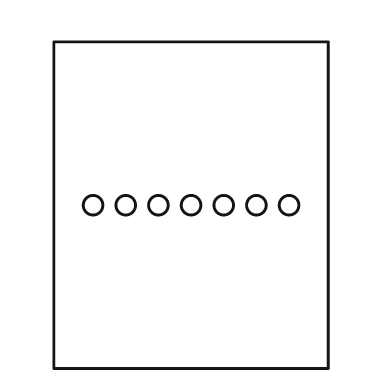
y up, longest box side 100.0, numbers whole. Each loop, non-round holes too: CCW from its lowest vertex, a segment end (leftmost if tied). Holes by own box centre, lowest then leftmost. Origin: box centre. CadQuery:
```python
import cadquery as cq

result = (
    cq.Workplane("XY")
    .moveTo(-42.0, -50.0)
    .lineTo(42.0, -50.0)
    .lineTo(42.0, 50.0)
    .lineTo(-42.0, 50.0)
    .close()
    .moveTo(-30.0, 0.0)
    .circle(3.0)
    .moveTo(-20.0, 0.0)
    .circle(3.0)
    .moveTo(-10.0, 0.0)
    .circle(3.0)
    .moveTo(0.0, 0.0)
    .circle(3.0)
    .moveTo(10.0, 0.0)
    .circle(3.0)
    .moveTo(20.0, 0.0)
    .circle(3.0)
    .moveTo(30.0, 0.0)
    .circle(3.0)
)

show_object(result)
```